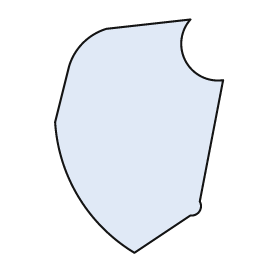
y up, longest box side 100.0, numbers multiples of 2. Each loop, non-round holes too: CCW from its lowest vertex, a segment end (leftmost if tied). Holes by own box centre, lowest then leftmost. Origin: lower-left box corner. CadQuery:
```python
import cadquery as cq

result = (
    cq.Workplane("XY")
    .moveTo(34.0, 0.0)
    .lineTo(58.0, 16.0)
    .threePointArc((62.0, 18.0), (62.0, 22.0))
    .lineTo(72.0, 74.0)
    .threePointArc((56.0, 82.0), (58.0, 100.0))
    .lineTo(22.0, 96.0)
    .threePointArc((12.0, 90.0), (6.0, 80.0))
    .lineTo(0.0, 56.0)
    .threePointArc((10.0, 24.0), (34.0, 0.0))
    .close()
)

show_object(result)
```